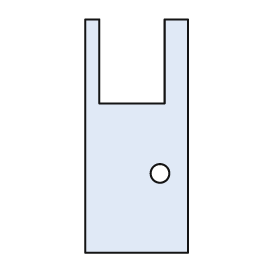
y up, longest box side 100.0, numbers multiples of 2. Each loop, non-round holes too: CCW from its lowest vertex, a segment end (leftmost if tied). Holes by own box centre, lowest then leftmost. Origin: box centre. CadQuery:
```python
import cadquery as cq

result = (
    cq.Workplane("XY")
    .moveTo(-22.0, -50.0)
    .lineTo(22.0, -50.0)
    .lineTo(22.0, 50.0)
    .lineTo(12.0, 50.0)
    .lineTo(12.0, 14.0)
    .lineTo(-16.0, 14.0)
    .lineTo(-16.0, 50.0)
    .lineTo(-22.0, 50.0)
    .close()
    .moveTo(10.0, -16.0)
    .circle(4.0)
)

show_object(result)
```